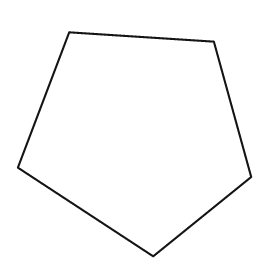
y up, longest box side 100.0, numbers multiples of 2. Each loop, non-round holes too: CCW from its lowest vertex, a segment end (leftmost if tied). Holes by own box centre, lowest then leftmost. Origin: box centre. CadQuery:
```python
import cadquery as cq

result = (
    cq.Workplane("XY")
    .moveTo(8.0, -48.0)
    .lineTo(50.0, -14.0)
    .lineTo(34.0, 44.0)
    .lineTo(-28.0, 48.0)
    .lineTo(-50.0, -10.0)
    .close()
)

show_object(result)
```